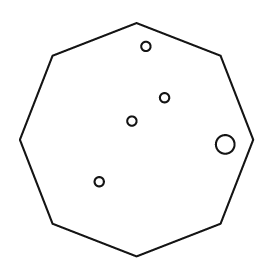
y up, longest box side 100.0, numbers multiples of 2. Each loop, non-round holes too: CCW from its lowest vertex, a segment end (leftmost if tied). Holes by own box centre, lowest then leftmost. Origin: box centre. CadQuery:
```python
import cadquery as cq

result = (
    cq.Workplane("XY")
    .moveTo(0.0, -50.0)
    .lineTo(36.0, -36.0)
    .lineTo(50.0, 0.0)
    .lineTo(36.0, 36.0)
    .lineTo(0.0, 50.0)
    .lineTo(-36.0, 36.0)
    .lineTo(-50.0, 0.0)
    .lineTo(-36.0, -36.0)
    .close()
    .moveTo(-16.0, -18.0)
    .circle(2.0)
    .moveTo(38.0, -2.0)
    .circle(4.0)
    .moveTo(-2.0, 8.0)
    .circle(2.0)
    .moveTo(12.0, 18.0)
    .circle(2.0)
    .moveTo(4.0, 40.0)
    .circle(2.0)
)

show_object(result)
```